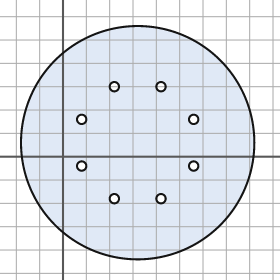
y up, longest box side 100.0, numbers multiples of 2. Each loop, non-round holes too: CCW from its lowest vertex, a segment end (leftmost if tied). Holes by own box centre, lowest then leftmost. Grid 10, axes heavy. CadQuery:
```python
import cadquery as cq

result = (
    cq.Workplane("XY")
    .moveTo(32.0, 6.0)
    .circle(50.0)
    .moveTo(22.0, -18.0)
    .circle(2.0)
    .moveTo(42.0, -18.0)
    .circle(2.0)
    .moveTo(8.0, -4.0)
    .circle(2.0)
    .moveTo(56.0, -4.0)
    .circle(2.0)
    .moveTo(8.0, 16.0)
    .circle(2.0)
    .moveTo(56.0, 16.0)
    .circle(2.0)
    .moveTo(22.0, 30.0)
    .circle(2.0)
    .moveTo(42.0, 30.0)
    .circle(2.0)
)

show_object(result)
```